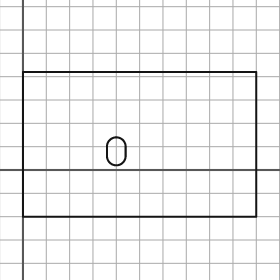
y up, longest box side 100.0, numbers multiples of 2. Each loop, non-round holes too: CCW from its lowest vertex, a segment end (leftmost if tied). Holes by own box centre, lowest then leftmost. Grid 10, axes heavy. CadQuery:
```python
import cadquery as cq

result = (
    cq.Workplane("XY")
    .moveTo(0.0, -20.0)
    .lineTo(100.0, -20.0)
    .lineTo(100.0, 42.0)
    .lineTo(0.0, 42.0)
    .close()
    .moveTo(36.0, 6.0)
    .threePointArc((40.0, 2.0), (44.0, 6.0))
    .lineTo(44.0, 10.0)
    .threePointArc((40.0, 14.0), (36.0, 10.0))
    .close()
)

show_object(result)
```